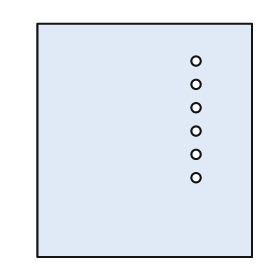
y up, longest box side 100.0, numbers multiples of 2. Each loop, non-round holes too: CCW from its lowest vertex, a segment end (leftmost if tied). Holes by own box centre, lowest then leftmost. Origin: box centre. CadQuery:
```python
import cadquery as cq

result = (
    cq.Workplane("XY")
    .moveTo(-46.0, -50.0)
    .lineTo(46.0, -50.0)
    .lineTo(46.0, 50.0)
    .lineTo(-46.0, 50.0)
    .close()
    .moveTo(22.0, -16.0)
    .circle(2.0)
    .moveTo(22.0, -6.0)
    .circle(2.0)
    .moveTo(22.0, 4.0)
    .circle(2.0)
    .moveTo(22.0, 14.0)
    .circle(2.0)
    .moveTo(22.0, 24.0)
    .circle(2.0)
    .moveTo(22.0, 34.0)
    .circle(2.0)
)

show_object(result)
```